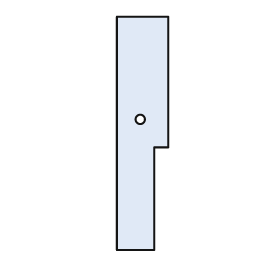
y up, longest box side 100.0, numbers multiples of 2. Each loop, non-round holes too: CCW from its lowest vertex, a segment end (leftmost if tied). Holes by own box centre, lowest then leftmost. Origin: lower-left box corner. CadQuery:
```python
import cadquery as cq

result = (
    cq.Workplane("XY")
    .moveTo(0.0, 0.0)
    .lineTo(16.0, 0.0)
    .lineTo(16.0, 44.0)
    .lineTo(22.0, 44.0)
    .lineTo(22.0, 100.0)
    .lineTo(0.0, 100.0)
    .close()
    .moveTo(10.0, 56.0)
    .circle(2.0)
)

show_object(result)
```